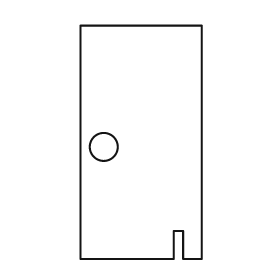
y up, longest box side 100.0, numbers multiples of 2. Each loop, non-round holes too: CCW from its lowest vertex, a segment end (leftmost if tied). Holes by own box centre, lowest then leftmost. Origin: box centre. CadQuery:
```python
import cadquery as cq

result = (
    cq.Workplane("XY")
    .moveTo(-26.0, -50.0)
    .lineTo(14.0, -50.0)
    .lineTo(14.0, -38.0)
    .lineTo(18.0, -38.0)
    .lineTo(18.0, -50.0)
    .lineTo(26.0, -50.0)
    .lineTo(26.0, 50.0)
    .lineTo(-26.0, 50.0)
    .close()
    .moveTo(-16.0, -2.0)
    .circle(6.0)
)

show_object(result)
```